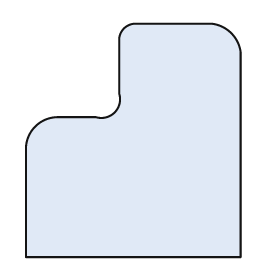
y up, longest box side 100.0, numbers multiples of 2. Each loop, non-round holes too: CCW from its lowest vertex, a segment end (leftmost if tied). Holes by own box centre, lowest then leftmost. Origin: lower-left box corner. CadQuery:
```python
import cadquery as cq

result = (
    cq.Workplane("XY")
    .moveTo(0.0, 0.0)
    .lineTo(92.0, 0.0)
    .lineTo(92.0, 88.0)
    .threePointArc((88.0, 96.0), (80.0, 100.0))
    .lineTo(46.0, 100.0)
    .threePointArc((42.0, 98.0), (40.0, 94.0))
    .lineTo(40.0, 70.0)
    .threePointArc((38.0, 62.0), (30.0, 60.0))
    .lineTo(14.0, 60.0)
    .threePointArc((4.0, 56.0), (0.0, 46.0))
    .close()
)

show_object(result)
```